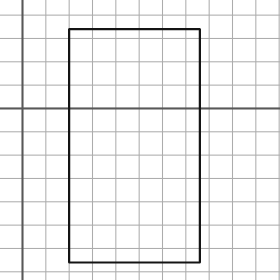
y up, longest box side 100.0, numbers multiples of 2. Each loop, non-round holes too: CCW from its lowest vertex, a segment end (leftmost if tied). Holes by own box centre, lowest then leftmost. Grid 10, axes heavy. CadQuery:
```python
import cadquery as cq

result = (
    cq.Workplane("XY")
    .moveTo(20.0, -66.0)
    .lineTo(76.0, -66.0)
    .lineTo(76.0, 34.0)
    .lineTo(20.0, 34.0)
    .close()
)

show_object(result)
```